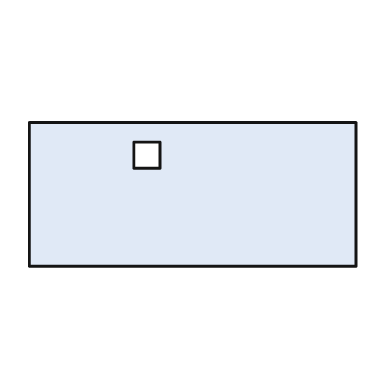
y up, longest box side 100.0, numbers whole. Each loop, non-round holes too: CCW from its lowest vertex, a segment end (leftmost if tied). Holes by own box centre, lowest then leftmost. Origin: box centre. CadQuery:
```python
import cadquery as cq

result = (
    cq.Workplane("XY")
    .moveTo(-50.0, -22.0)
    .lineTo(50.0, -22.0)
    .lineTo(50.0, 22.0)
    .lineTo(-50.0, 22.0)
    .close()
    .moveTo(-18.0, 8.0)
    .lineTo(-10.0, 8.0)
    .lineTo(-10.0, 16.0)
    .lineTo(-18.0, 16.0)
    .close()
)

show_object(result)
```